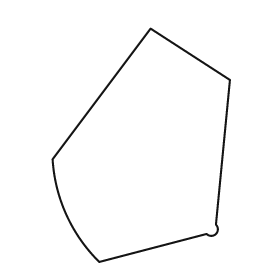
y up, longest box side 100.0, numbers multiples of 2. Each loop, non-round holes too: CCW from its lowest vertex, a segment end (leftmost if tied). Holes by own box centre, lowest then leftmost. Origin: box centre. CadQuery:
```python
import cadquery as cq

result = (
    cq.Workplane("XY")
    .moveTo(-18.0, -50.0)
    .lineTo(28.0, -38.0)
    .threePointArc((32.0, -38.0), (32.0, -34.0))
    .lineTo(38.0, 28.0)
    .lineTo(4.0, 50.0)
    .lineTo(-38.0, -6.0)
    .threePointArc((-32.0, -30.0), (-18.0, -50.0))
    .close()
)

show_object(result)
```